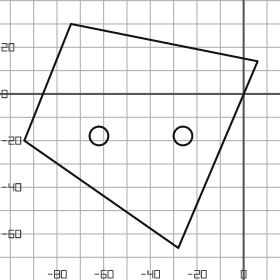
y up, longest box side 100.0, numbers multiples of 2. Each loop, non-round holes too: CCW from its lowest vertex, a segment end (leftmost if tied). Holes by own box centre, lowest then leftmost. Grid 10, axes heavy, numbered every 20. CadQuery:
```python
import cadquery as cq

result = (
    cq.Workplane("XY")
    .moveTo(-28.0, -66.0)
    .lineTo(6.0, 14.0)
    .lineTo(-74.0, 30.0)
    .lineTo(-94.0, -20.0)
    .close()
    .moveTo(-62.0, -18.0)
    .circle(4.0)
    .moveTo(-26.0, -18.0)
    .circle(4.0)
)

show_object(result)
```